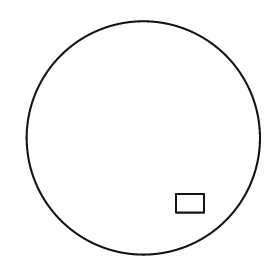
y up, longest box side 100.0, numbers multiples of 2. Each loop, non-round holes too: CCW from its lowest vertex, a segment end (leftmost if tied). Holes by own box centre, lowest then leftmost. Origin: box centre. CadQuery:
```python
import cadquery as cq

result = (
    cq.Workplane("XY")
    .moveTo(0.0, 0.0)
    .circle(50.0)
    .moveTo(14.0, -32.0)
    .lineTo(26.0, -32.0)
    .lineTo(26.0, -24.0)
    .lineTo(14.0, -24.0)
    .close()
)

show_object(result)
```